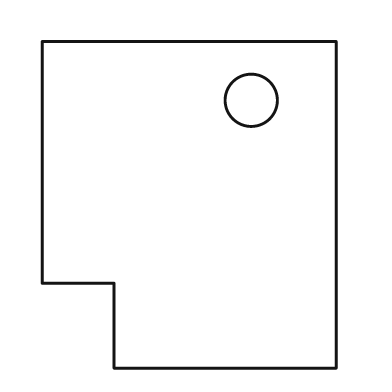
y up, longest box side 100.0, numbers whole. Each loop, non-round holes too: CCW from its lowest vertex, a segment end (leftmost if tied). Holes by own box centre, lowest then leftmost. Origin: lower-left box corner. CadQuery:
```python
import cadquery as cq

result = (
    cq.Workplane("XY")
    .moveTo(22.0, 0.0)
    .lineTo(90.0, 0.0)
    .lineTo(90.0, 100.0)
    .lineTo(0.0, 100.0)
    .lineTo(0.0, 26.0)
    .lineTo(22.0, 26.0)
    .close()
    .moveTo(64.0, 82.0)
    .circle(8.0)
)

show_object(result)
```